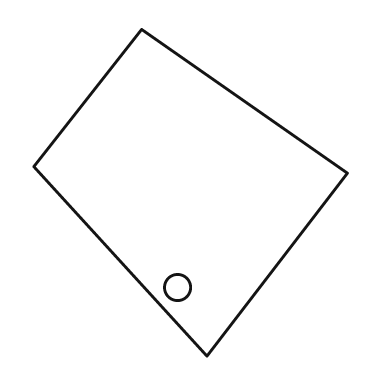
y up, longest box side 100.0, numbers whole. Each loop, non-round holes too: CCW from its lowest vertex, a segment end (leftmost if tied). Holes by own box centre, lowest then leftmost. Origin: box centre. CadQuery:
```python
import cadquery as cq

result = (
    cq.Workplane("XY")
    .moveTo(5.0, -50.0)
    .lineTo(48.0, 6.0)
    .lineTo(-15.0, 50.0)
    .lineTo(-48.0, 8.0)
    .close()
    .moveTo(-4.0, -29.0)
    .circle(4.0)
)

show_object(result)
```